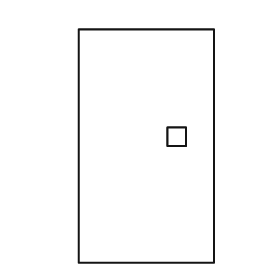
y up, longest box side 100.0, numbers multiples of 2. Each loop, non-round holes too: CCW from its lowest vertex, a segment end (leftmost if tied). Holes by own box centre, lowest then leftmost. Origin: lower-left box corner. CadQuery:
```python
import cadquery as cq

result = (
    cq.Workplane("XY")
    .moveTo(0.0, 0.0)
    .lineTo(58.0, 0.0)
    .lineTo(58.0, 100.0)
    .lineTo(0.0, 100.0)
    .close()
    .moveTo(38.0, 50.0)
    .lineTo(46.0, 50.0)
    .lineTo(46.0, 58.0)
    .lineTo(38.0, 58.0)
    .close()
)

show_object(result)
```